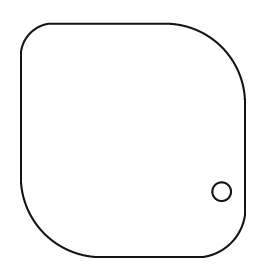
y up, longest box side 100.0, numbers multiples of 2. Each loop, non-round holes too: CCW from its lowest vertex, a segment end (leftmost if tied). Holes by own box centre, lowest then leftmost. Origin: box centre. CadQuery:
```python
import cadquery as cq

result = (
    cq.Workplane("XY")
    .moveTo(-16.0, -50.0)
    .lineTo(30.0, -50.0)
    .threePointArc((42.0, -44.0), (48.0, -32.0))
    .lineTo(48.0, 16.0)
    .threePointArc((38.0, 40.0), (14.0, 50.0))
    .lineTo(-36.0, 50.0)
    .threePointArc((-44.0, 46.0), (-48.0, 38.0))
    .lineTo(-48.0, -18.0)
    .threePointArc((-38.0, -40.0), (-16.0, -50.0))
    .close()
    .moveTo(38.0, -22.0)
    .circle(4.0)
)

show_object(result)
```